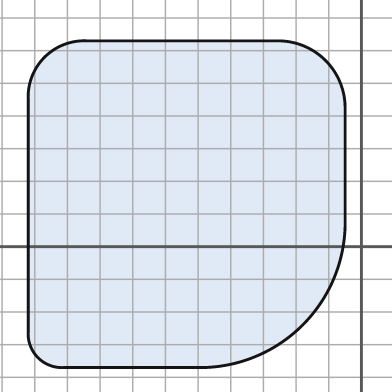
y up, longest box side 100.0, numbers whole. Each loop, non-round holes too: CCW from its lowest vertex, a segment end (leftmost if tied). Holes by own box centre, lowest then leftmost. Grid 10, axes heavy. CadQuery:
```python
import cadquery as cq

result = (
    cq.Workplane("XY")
    .moveTo(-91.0, -37.0)
    .lineTo(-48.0, -37.0)
    .threePointArc((-18.0, -24.0), (-5.0, 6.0))
    .lineTo(-5.0, 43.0)
    .threePointArc((-11.0, 57.0), (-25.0, 63.0))
    .lineTo(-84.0, 63.0)
    .threePointArc((-97.0, 58.0), (-102.0, 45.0))
    .lineTo(-102.0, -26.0)
    .threePointArc((-99.0, -34.0), (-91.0, -37.0))
    .close()
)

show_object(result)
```